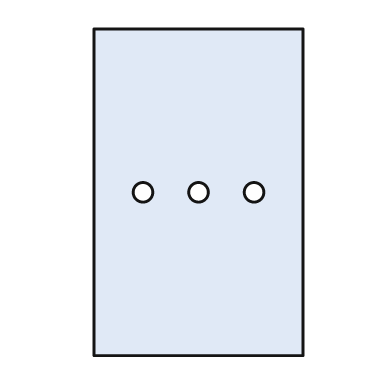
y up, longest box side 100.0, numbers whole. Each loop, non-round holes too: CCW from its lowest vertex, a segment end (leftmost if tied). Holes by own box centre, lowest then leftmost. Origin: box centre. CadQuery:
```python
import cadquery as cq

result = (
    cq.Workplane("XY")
    .moveTo(-32.0, -50.0)
    .lineTo(32.0, -50.0)
    .lineTo(32.0, 50.0)
    .lineTo(-32.0, 50.0)
    .close()
    .moveTo(-17.0, 0.0)
    .circle(3.0)
    .moveTo(0.0, 0.0)
    .circle(3.0)
    .moveTo(17.0, 0.0)
    .circle(3.0)
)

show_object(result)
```